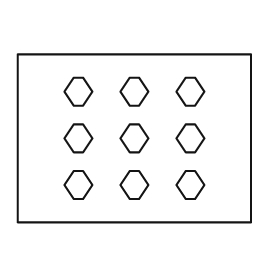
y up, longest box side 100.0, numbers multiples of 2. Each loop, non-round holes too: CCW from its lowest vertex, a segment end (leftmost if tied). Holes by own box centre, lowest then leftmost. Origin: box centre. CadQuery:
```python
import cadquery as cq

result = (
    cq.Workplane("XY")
    .moveTo(-50.0, -36.0)
    .lineTo(50.0, -36.0)
    .lineTo(50.0, 36.0)
    .lineTo(-50.0, 36.0)
    .close()
    .moveTo(-26.0, -26.0)
    .lineTo(-22.0, -26.0)
    .lineTo(-18.0, -20.0)
    .lineTo(-22.0, -14.0)
    .lineTo(-26.0, -14.0)
    .lineTo(-30.0, -20.0)
    .close()
    .moveTo(-2.0, -26.0)
    .lineTo(2.0, -26.0)
    .lineTo(6.0, -20.0)
    .lineTo(2.0, -14.0)
    .lineTo(-2.0, -14.0)
    .lineTo(-6.0, -20.0)
    .close()
    .moveTo(22.0, -26.0)
    .lineTo(26.0, -26.0)
    .lineTo(30.0, -20.0)
    .lineTo(26.0, -14.0)
    .lineTo(22.0, -14.0)
    .lineTo(18.0, -20.0)
    .close()
    .moveTo(-26.0, -6.0)
    .lineTo(-22.0, -6.0)
    .lineTo(-18.0, 0.0)
    .lineTo(-22.0, 6.0)
    .lineTo(-26.0, 6.0)
    .lineTo(-30.0, 0.0)
    .close()
    .moveTo(-2.0, -6.0)
    .lineTo(2.0, -6.0)
    .lineTo(6.0, 0.0)
    .lineTo(2.0, 6.0)
    .lineTo(-2.0, 6.0)
    .lineTo(-6.0, 0.0)
    .close()
    .moveTo(22.0, -6.0)
    .lineTo(26.0, -6.0)
    .lineTo(30.0, 0.0)
    .lineTo(26.0, 6.0)
    .lineTo(22.0, 6.0)
    .lineTo(18.0, 0.0)
    .close()
    .moveTo(-26.0, 14.0)
    .lineTo(-22.0, 14.0)
    .lineTo(-18.0, 20.0)
    .lineTo(-22.0, 26.0)
    .lineTo(-26.0, 26.0)
    .lineTo(-30.0, 20.0)
    .close()
    .moveTo(-2.0, 14.0)
    .lineTo(2.0, 14.0)
    .lineTo(6.0, 20.0)
    .lineTo(2.0, 26.0)
    .lineTo(-2.0, 26.0)
    .lineTo(-6.0, 20.0)
    .close()
    .moveTo(22.0, 14.0)
    .lineTo(26.0, 14.0)
    .lineTo(30.0, 20.0)
    .lineTo(26.0, 26.0)
    .lineTo(22.0, 26.0)
    .lineTo(18.0, 20.0)
    .close()
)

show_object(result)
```